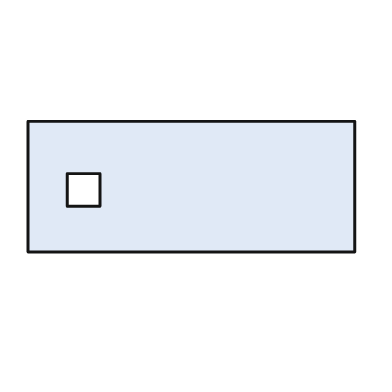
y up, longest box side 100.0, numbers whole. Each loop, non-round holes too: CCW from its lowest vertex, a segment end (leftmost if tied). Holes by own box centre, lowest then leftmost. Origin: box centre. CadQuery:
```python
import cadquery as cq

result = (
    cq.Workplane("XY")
    .moveTo(-50.0, -20.0)
    .lineTo(50.0, -20.0)
    .lineTo(50.0, 20.0)
    .lineTo(-50.0, 20.0)
    .close()
    .moveTo(-38.0, -6.0)
    .lineTo(-28.0, -6.0)
    .lineTo(-28.0, 4.0)
    .lineTo(-38.0, 4.0)
    .close()
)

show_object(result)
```